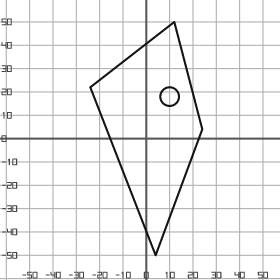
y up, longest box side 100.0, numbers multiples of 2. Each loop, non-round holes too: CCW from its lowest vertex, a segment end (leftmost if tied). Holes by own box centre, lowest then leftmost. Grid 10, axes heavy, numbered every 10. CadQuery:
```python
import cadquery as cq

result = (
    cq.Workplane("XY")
    .moveTo(4.0, -50.0)
    .lineTo(24.0, 4.0)
    .lineTo(12.0, 50.0)
    .lineTo(-24.0, 22.0)
    .close()
    .moveTo(10.0, 18.0)
    .circle(4.0)
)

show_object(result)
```